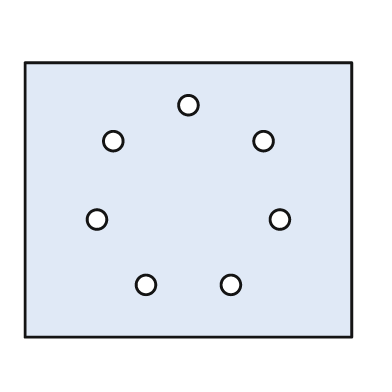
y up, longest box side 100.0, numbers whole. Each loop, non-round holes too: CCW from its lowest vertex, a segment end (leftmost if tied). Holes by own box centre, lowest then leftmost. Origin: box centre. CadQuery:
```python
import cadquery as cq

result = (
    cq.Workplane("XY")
    .moveTo(-50.0, -42.0)
    .lineTo(50.0, -42.0)
    .lineTo(50.0, 42.0)
    .lineTo(-50.0, 42.0)
    .close()
    .moveTo(-13.0, -26.0)
    .circle(3.0)
    .moveTo(13.0, -26.0)
    .circle(3.0)
    .moveTo(-28.0, -6.0)
    .circle(3.0)
    .moveTo(28.0, -6.0)
    .circle(3.0)
    .moveTo(-23.0, 18.0)
    .circle(3.0)
    .moveTo(23.0, 18.0)
    .circle(3.0)
    .moveTo(0.0, 29.0)
    .circle(3.0)
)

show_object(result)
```